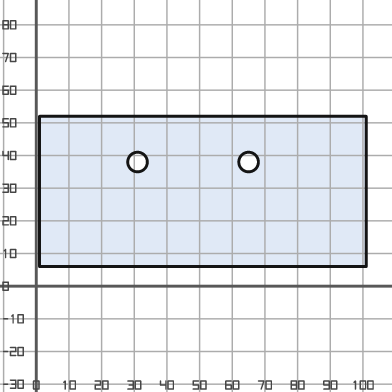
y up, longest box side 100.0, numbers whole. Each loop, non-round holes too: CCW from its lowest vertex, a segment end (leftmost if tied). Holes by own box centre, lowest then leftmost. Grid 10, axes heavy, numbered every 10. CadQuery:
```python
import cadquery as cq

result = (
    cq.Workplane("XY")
    .moveTo(1.0, 6.0)
    .lineTo(101.0, 6.0)
    .lineTo(101.0, 52.0)
    .lineTo(1.0, 52.0)
    .close()
    .moveTo(31.0, 38.0)
    .circle(3.0)
    .moveTo(65.0, 38.0)
    .circle(3.0)
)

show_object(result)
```